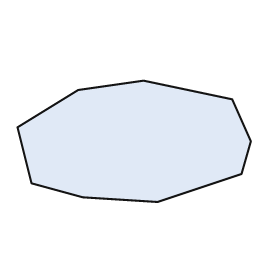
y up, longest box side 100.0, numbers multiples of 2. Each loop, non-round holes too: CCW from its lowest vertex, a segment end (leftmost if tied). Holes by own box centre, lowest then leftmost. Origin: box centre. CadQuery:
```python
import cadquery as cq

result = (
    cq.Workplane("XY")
    .moveTo(10.0, -26.0)
    .lineTo(46.0, -14.0)
    .lineTo(50.0, 0.0)
    .lineTo(42.0, 18.0)
    .lineTo(4.0, 26.0)
    .lineTo(-24.0, 22.0)
    .lineTo(-50.0, 6.0)
    .lineTo(-44.0, -18.0)
    .lineTo(-22.0, -24.0)
    .close()
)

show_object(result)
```